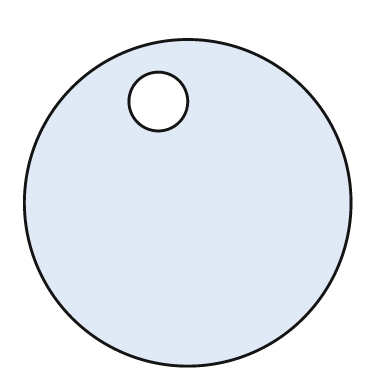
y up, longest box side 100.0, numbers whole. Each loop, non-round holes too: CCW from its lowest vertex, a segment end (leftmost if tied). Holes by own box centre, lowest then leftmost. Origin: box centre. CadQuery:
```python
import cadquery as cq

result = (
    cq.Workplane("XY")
    .moveTo(0.0, 0.0)
    .circle(50.0)
    .moveTo(-9.0, 31.0)
    .circle(9.0)
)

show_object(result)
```